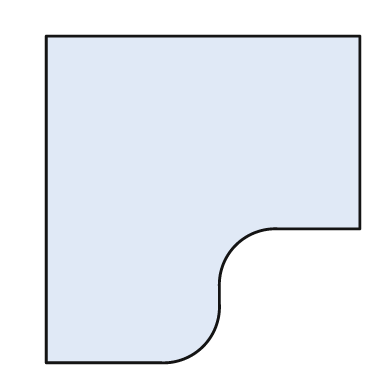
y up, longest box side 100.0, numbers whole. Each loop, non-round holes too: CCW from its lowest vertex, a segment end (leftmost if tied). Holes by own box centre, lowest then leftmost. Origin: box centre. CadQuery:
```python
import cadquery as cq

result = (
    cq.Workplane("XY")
    .moveTo(-48.0, -50.0)
    .lineTo(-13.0, -50.0)
    .threePointArc((0.0, -45.0), (5.0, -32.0))
    .lineTo(5.0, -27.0)
    .threePointArc((10.0, -14.0), (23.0, -9.0))
    .lineTo(48.0, -9.0)
    .lineTo(48.0, 50.0)
    .lineTo(-48.0, 50.0)
    .close()
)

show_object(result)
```